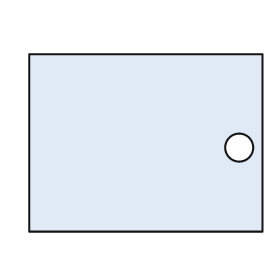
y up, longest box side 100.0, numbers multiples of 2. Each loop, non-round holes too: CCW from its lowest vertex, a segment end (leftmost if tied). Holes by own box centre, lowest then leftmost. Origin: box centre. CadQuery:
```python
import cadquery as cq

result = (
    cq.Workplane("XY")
    .moveTo(-50.0, -38.0)
    .lineTo(50.0, -38.0)
    .lineTo(50.0, 38.0)
    .lineTo(-50.0, 38.0)
    .close()
    .moveTo(40.0, -2.0)
    .circle(6.0)
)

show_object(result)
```